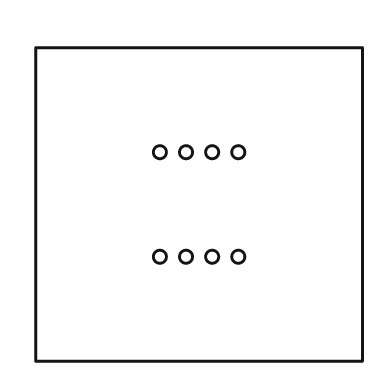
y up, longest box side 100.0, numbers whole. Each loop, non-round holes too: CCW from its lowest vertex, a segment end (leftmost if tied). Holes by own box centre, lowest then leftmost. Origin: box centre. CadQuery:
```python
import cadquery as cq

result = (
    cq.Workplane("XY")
    .moveTo(-50.0, -48.0)
    .lineTo(50.0, -48.0)
    .lineTo(50.0, 48.0)
    .lineTo(-50.0, 48.0)
    .close()
    .moveTo(-12.0, -16.0)
    .circle(2.0)
    .moveTo(-4.0, -16.0)
    .circle(2.0)
    .moveTo(4.0, -16.0)
    .circle(2.0)
    .moveTo(12.0, -16.0)
    .circle(2.0)
    .moveTo(-12.0, 16.0)
    .circle(2.0)
    .moveTo(-4.0, 16.0)
    .circle(2.0)
    .moveTo(4.0, 16.0)
    .circle(2.0)
    .moveTo(12.0, 16.0)
    .circle(2.0)
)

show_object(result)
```